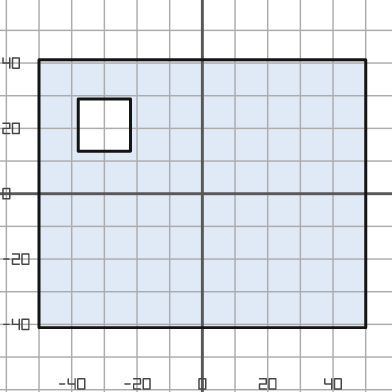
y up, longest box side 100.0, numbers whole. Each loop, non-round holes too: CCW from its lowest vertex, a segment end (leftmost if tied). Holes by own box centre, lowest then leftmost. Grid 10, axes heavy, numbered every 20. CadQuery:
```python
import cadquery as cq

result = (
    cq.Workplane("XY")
    .moveTo(-50.0, -41.0)
    .lineTo(50.0, -41.0)
    .lineTo(50.0, 41.0)
    .lineTo(-50.0, 41.0)
    .close()
    .moveTo(-38.0, 13.0)
    .lineTo(-22.0, 13.0)
    .lineTo(-22.0, 29.0)
    .lineTo(-38.0, 29.0)
    .close()
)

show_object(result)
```